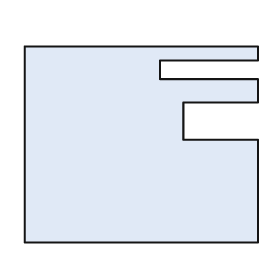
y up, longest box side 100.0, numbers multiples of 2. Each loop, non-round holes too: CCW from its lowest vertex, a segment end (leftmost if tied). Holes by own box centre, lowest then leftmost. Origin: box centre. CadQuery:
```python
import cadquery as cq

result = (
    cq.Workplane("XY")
    .moveTo(-50.0, -42.0)
    .lineTo(50.0, -42.0)
    .lineTo(50.0, 2.0)
    .lineTo(18.0, 2.0)
    .lineTo(18.0, 18.0)
    .lineTo(50.0, 18.0)
    .lineTo(50.0, 28.0)
    .lineTo(8.0, 28.0)
    .lineTo(8.0, 36.0)
    .lineTo(50.0, 36.0)
    .lineTo(50.0, 42.0)
    .lineTo(-50.0, 42.0)
    .close()
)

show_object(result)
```